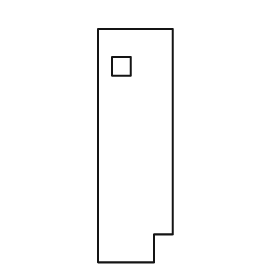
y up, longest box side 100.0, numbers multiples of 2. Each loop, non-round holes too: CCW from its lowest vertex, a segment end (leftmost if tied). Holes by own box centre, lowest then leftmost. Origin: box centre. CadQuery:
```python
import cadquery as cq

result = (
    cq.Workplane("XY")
    .moveTo(-16.0, -50.0)
    .lineTo(8.0, -50.0)
    .lineTo(8.0, -38.0)
    .lineTo(16.0, -38.0)
    .lineTo(16.0, 50.0)
    .lineTo(-16.0, 50.0)
    .close()
    .moveTo(-10.0, 30.0)
    .lineTo(-2.0, 30.0)
    .lineTo(-2.0, 38.0)
    .lineTo(-10.0, 38.0)
    .close()
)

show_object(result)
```